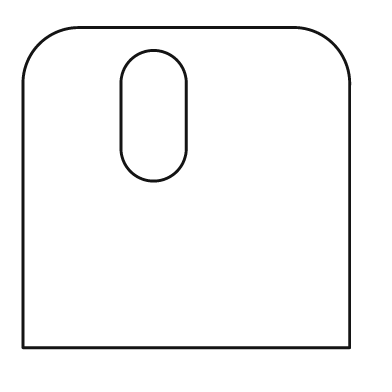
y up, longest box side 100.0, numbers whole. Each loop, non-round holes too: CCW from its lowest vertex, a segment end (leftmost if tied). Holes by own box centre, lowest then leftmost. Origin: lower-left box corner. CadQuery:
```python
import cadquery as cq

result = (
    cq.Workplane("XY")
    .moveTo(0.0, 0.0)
    .lineTo(100.0, 0.0)
    .lineTo(100.0, 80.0)
    .threePointArc((95.0, 93.0), (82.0, 98.0))
    .lineTo(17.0, 98.0)
    .threePointArc((5.0, 93.0), (0.0, 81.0))
    .close()
    .moveTo(30.0, 61.0)
    .threePointArc((40.0, 51.0), (50.0, 61.0))
    .lineTo(50.0, 81.0)
    .threePointArc((40.0, 91.0), (30.0, 81.0))
    .close()
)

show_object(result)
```